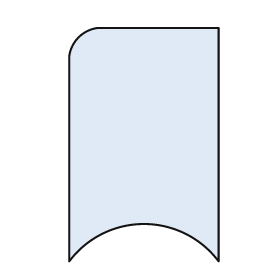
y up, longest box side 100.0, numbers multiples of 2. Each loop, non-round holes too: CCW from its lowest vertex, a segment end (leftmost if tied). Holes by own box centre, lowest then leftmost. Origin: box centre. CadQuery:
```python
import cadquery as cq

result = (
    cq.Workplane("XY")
    .moveTo(-32.0, -50.0)
    .threePointArc((0.0, -34.0), (32.0, -50.0))
    .lineTo(32.0, 50.0)
    .lineTo(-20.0, 50.0)
    .threePointArc((-28.0, 46.0), (-32.0, 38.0))
    .close()
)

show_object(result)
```